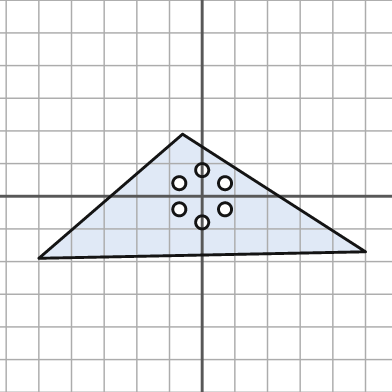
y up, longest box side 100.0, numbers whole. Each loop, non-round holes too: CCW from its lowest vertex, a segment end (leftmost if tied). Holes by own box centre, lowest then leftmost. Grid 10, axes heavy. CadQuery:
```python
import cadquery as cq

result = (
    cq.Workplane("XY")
    .moveTo(-50.0, -19.0)
    .lineTo(50.0, -17.0)
    .lineTo(-6.0, 19.0)
    .close()
    .moveTo(0.0, -8.0)
    .circle(2.0)
    .moveTo(-7.0, -4.0)
    .circle(2.0)
    .moveTo(7.0, -4.0)
    .circle(2.0)
    .moveTo(-7.0, 4.0)
    .circle(2.0)
    .moveTo(7.0, 4.0)
    .circle(2.0)
    .moveTo(0.0, 8.0)
    .circle(2.0)
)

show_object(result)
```